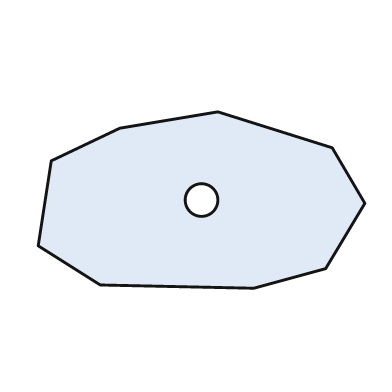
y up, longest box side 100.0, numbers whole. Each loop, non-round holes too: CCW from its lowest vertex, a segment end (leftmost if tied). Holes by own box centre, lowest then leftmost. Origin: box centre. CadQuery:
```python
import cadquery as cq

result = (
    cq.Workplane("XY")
    .moveTo(16.0, -27.0)
    .lineTo(38.0, -21.0)
    .lineTo(50.0, -1.0)
    .lineTo(40.0, 16.0)
    .lineTo(5.0, 27.0)
    .lineTo(-25.0, 22.0)
    .lineTo(-46.0, 12.0)
    .lineTo(-50.0, -14.0)
    .lineTo(-31.0, -26.0)
    .close()
    .moveTo(0.0, 0.0)
    .circle(5.0)
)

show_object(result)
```